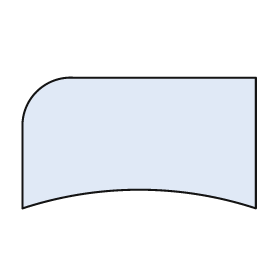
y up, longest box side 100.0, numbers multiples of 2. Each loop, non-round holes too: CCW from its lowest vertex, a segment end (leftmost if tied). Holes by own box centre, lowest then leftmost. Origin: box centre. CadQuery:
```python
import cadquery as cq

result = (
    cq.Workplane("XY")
    .moveTo(-50.0, -28.0)
    .threePointArc((0.0, -20.0), (50.0, -28.0))
    .lineTo(50.0, 28.0)
    .lineTo(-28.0, 28.0)
    .threePointArc((-44.0, 22.0), (-50.0, 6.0))
    .close()
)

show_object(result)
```